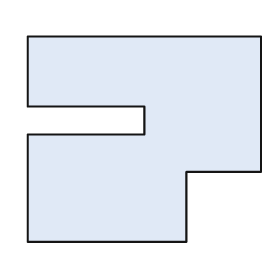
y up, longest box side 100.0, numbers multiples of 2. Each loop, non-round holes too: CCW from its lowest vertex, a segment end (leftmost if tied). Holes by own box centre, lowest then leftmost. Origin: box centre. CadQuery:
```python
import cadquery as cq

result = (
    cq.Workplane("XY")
    .moveTo(-50.0, -44.0)
    .lineTo(18.0, -44.0)
    .lineTo(18.0, -14.0)
    .lineTo(50.0, -14.0)
    .lineTo(50.0, 44.0)
    .lineTo(-50.0, 44.0)
    .lineTo(-50.0, 14.0)
    .lineTo(0.0, 14.0)
    .lineTo(0.0, 2.0)
    .lineTo(-50.0, 2.0)
    .close()
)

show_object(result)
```